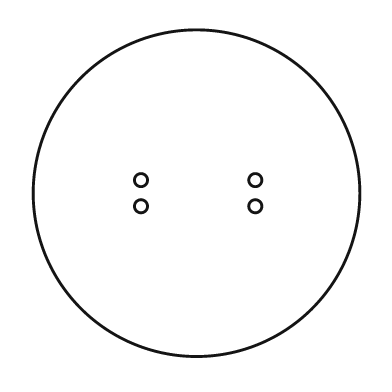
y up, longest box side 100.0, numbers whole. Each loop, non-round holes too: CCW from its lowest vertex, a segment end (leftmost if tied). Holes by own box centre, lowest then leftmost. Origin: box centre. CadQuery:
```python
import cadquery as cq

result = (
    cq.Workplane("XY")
    .moveTo(0.0, 0.0)
    .circle(50.0)
    .moveTo(-17.0, -4.0)
    .circle(2.0)
    .moveTo(18.0, -4.0)
    .circle(2.0)
    .moveTo(-17.0, 4.0)
    .circle(2.0)
    .moveTo(18.0, 4.0)
    .circle(2.0)
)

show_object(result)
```